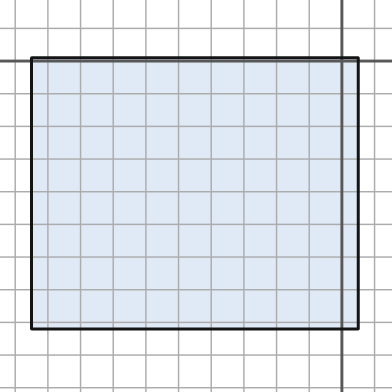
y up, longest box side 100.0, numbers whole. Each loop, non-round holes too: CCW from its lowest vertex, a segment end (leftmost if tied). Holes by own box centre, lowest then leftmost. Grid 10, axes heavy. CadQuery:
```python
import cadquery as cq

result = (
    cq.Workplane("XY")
    .moveTo(-95.0, -82.0)
    .lineTo(5.0, -82.0)
    .lineTo(5.0, 1.0)
    .lineTo(-95.0, 1.0)
    .close()
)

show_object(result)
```